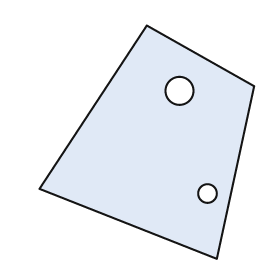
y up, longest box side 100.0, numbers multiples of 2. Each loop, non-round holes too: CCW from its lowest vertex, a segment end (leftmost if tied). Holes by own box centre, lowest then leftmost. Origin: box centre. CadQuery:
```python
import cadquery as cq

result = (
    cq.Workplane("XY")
    .moveTo(30.0, -50.0)
    .lineTo(46.0, 24.0)
    .lineTo(0.0, 50.0)
    .lineTo(-46.0, -20.0)
    .close()
    .moveTo(26.0, -22.0)
    .circle(4.0)
    .moveTo(14.0, 22.0)
    .circle(6.0)
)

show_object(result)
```